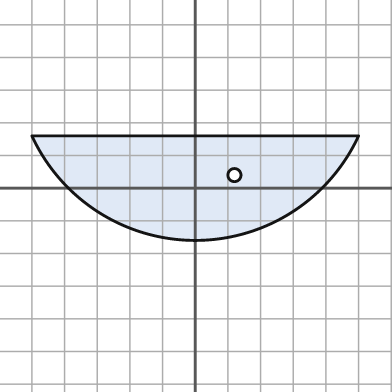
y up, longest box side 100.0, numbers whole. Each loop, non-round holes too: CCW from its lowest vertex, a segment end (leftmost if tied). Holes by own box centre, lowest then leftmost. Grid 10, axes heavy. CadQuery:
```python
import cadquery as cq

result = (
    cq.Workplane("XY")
    .moveTo(-50.0, 16.0)
    .threePointArc((0.0, -16.0), (50.0, 16.0))
    .close()
    .moveTo(12.0, 4.0)
    .circle(2.0)
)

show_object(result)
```